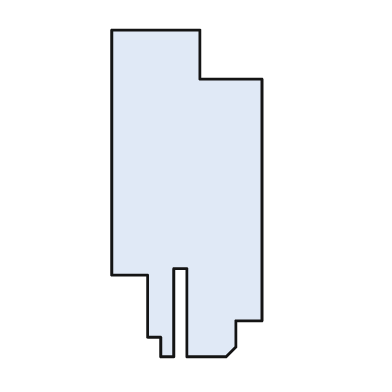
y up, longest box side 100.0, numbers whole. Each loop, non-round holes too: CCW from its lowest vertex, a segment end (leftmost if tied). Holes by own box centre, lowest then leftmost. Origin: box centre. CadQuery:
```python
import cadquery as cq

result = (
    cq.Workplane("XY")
    .moveTo(-8.0, -50.0)
    .lineTo(-4.0, -50.0)
    .lineTo(-4.0, -23.0)
    .lineTo(0.0, -23.0)
    .lineTo(0.0, -50.0)
    .lineTo(12.0, -50.0)
    .lineTo(15.0, -47.0)
    .lineTo(15.0, -39.0)
    .lineTo(23.0, -39.0)
    .lineTo(23.0, 35.0)
    .lineTo(4.0, 35.0)
    .lineTo(4.0, 50.0)
    .lineTo(-23.0, 50.0)
    .lineTo(-23.0, -25.0)
    .lineTo(-12.0, -25.0)
    .lineTo(-12.0, -44.0)
    .lineTo(-8.0, -44.0)
    .close()
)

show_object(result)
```